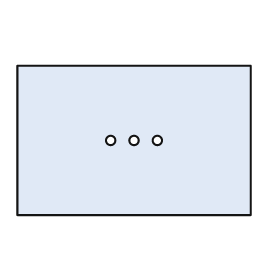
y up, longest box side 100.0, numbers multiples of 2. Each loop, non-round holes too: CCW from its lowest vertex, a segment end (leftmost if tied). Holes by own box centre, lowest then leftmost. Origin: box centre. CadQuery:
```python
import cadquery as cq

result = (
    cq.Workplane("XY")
    .moveTo(-50.0, -32.0)
    .lineTo(50.0, -32.0)
    .lineTo(50.0, 32.0)
    .lineTo(-50.0, 32.0)
    .close()
    .moveTo(-10.0, 0.0)
    .circle(2.0)
    .moveTo(0.0, 0.0)
    .circle(2.0)
    .moveTo(10.0, 0.0)
    .circle(2.0)
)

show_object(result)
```